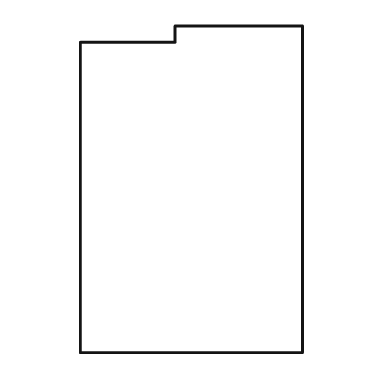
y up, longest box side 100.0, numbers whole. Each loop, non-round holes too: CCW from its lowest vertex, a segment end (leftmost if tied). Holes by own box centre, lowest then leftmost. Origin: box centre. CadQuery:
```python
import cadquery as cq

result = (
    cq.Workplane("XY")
    .moveTo(-34.0, -50.0)
    .lineTo(34.0, -50.0)
    .lineTo(34.0, 50.0)
    .lineTo(-5.0, 50.0)
    .lineTo(-5.0, 45.0)
    .lineTo(-34.0, 45.0)
    .close()
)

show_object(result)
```